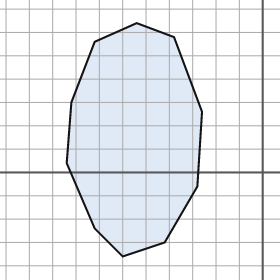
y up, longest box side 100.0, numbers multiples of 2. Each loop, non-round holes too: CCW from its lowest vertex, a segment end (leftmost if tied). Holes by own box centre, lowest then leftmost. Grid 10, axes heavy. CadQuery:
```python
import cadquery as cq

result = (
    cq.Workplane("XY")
    .moveTo(-60.0, -36.0)
    .lineTo(-42.0, -30.0)
    .lineTo(-28.0, -6.0)
    .lineTo(-26.0, 26.0)
    .lineTo(-38.0, 58.0)
    .lineTo(-54.0, 64.0)
    .lineTo(-72.0, 56.0)
    .lineTo(-82.0, 30.0)
    .lineTo(-84.0, 4.0)
    .lineTo(-72.0, -24.0)
    .close()
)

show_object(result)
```